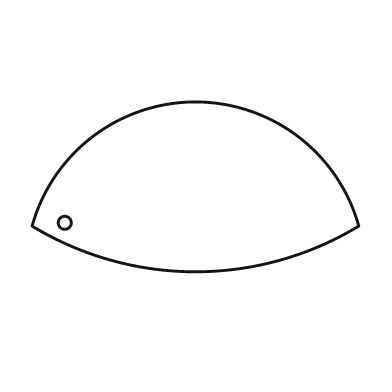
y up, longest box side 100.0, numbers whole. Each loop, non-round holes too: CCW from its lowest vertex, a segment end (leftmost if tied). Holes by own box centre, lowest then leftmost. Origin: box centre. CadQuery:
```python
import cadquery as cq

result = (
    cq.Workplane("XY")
    .moveTo(-50.0, -12.0)
    .threePointArc((0.0, -26.0), (50.0, -12.0))
    .threePointArc((0.0, 26.0), (-50.0, -12.0))
    .close()
    .moveTo(-40.0, -11.0)
    .circle(2.0)
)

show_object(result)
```